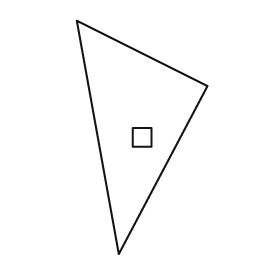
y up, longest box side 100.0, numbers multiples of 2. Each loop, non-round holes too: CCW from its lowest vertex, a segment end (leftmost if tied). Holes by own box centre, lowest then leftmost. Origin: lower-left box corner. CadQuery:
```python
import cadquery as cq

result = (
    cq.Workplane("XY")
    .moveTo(18.0, 0.0)
    .lineTo(56.0, 72.0)
    .lineTo(0.0, 100.0)
    .close()
    .moveTo(24.0, 46.0)
    .lineTo(32.0, 46.0)
    .lineTo(32.0, 54.0)
    .lineTo(24.0, 54.0)
    .close()
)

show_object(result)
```